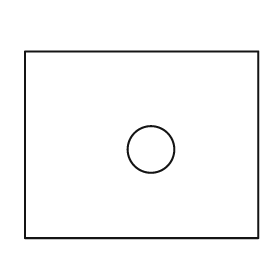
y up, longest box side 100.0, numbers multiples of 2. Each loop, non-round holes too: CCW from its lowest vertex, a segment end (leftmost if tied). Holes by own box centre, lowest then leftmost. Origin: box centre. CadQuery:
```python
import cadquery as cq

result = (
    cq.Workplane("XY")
    .moveTo(-50.0, -40.0)
    .lineTo(50.0, -40.0)
    .lineTo(50.0, 40.0)
    .lineTo(-50.0, 40.0)
    .close()
    .moveTo(4.0, -2.0)
    .circle(10.0)
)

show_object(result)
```